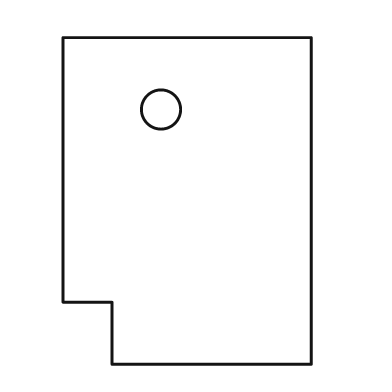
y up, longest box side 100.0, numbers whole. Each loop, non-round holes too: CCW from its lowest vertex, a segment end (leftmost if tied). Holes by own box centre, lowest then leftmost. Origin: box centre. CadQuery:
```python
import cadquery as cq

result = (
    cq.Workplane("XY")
    .moveTo(-23.0, -50.0)
    .lineTo(38.0, -50.0)
    .lineTo(38.0, 50.0)
    .lineTo(-38.0, 50.0)
    .lineTo(-38.0, -31.0)
    .lineTo(-23.0, -31.0)
    .close()
    .moveTo(-8.0, 28.0)
    .circle(6.0)
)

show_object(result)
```